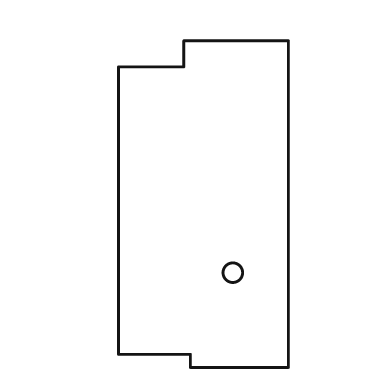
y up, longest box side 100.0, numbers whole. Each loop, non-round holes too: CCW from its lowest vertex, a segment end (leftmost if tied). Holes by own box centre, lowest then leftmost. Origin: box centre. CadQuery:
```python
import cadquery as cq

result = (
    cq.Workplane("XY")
    .moveTo(-4.0, -50.0)
    .lineTo(26.0, -50.0)
    .lineTo(26.0, 50.0)
    .lineTo(-6.0, 50.0)
    .lineTo(-6.0, 42.0)
    .lineTo(-26.0, 42.0)
    .lineTo(-26.0, -46.0)
    .lineTo(-4.0, -46.0)
    .close()
    .moveTo(9.0, -21.0)
    .circle(3.0)
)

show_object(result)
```